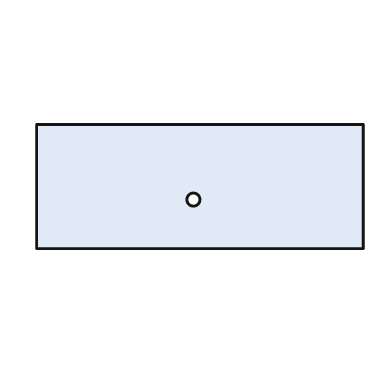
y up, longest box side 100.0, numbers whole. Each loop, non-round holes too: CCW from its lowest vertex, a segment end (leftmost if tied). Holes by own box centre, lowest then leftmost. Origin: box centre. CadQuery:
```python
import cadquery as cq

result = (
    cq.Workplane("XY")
    .moveTo(-50.0, -19.0)
    .lineTo(50.0, -19.0)
    .lineTo(50.0, 19.0)
    .lineTo(-50.0, 19.0)
    .close()
    .moveTo(-2.0, -4.0)
    .circle(2.0)
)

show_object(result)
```